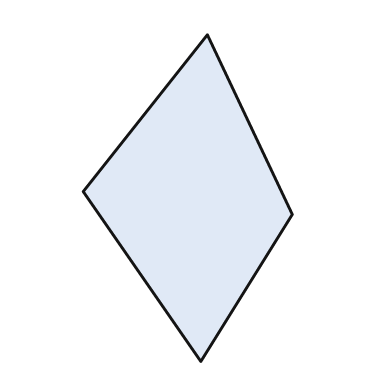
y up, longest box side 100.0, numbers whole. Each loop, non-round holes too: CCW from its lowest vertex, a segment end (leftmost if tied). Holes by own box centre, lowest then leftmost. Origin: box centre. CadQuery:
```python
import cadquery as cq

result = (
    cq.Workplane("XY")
    .moveTo(4.0, -50.0)
    .lineTo(32.0, -5.0)
    .lineTo(6.0, 50.0)
    .lineTo(-32.0, 2.0)
    .close()
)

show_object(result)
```